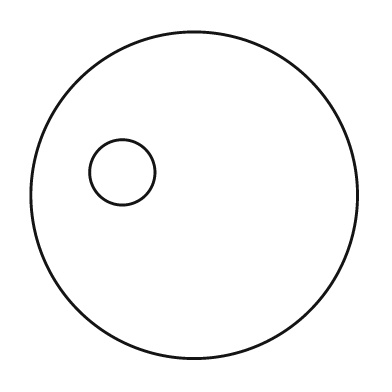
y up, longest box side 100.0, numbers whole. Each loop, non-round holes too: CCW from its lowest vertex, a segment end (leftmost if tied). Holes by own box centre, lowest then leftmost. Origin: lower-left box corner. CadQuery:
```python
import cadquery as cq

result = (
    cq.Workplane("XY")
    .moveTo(50.0, 50.0)
    .circle(50.0)
    .moveTo(28.0, 57.0)
    .circle(10.0)
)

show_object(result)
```